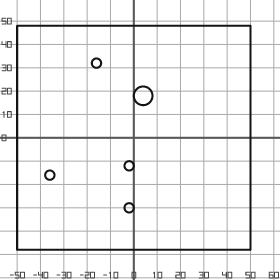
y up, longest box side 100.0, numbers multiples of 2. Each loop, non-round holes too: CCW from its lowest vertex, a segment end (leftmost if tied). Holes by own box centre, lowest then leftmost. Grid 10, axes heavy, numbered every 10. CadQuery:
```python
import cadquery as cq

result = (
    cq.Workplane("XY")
    .moveTo(-50.0, -48.0)
    .lineTo(50.0, -48.0)
    .lineTo(50.0, 48.0)
    .lineTo(-50.0, 48.0)
    .close()
    .moveTo(-2.0, -30.0)
    .circle(2.0)
    .moveTo(-36.0, -16.0)
    .circle(2.0)
    .moveTo(-2.0, -12.0)
    .circle(2.0)
    .moveTo(4.0, 18.0)
    .circle(4.0)
    .moveTo(-16.0, 32.0)
    .circle(2.0)
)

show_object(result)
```